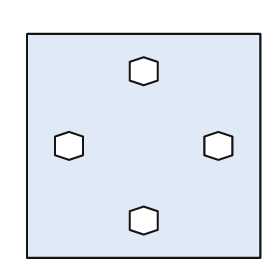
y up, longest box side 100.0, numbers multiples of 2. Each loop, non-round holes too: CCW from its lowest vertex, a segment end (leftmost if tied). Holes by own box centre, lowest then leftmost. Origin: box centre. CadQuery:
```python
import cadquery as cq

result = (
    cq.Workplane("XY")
    .moveTo(-50.0, -48.0)
    .lineTo(50.0, -48.0)
    .lineTo(50.0, 48.0)
    .lineTo(-50.0, 48.0)
    .close()
    .moveTo(0.0, -38.0)
    .lineTo(6.0, -36.0)
    .lineTo(6.0, -28.0)
    .lineTo(0.0, -26.0)
    .lineTo(-6.0, -28.0)
    .lineTo(-6.0, -36.0)
    .close()
    .moveTo(-32.0, -6.0)
    .lineTo(-26.0, -4.0)
    .lineTo(-26.0, 4.0)
    .lineTo(-32.0, 6.0)
    .lineTo(-38.0, 4.0)
    .lineTo(-38.0, -4.0)
    .close()
    .moveTo(32.0, -6.0)
    .lineTo(38.0, -4.0)
    .lineTo(38.0, 4.0)
    .lineTo(32.0, 6.0)
    .lineTo(26.0, 4.0)
    .lineTo(26.0, -4.0)
    .close()
    .moveTo(0.0, 26.0)
    .lineTo(6.0, 28.0)
    .lineTo(6.0, 36.0)
    .lineTo(0.0, 38.0)
    .lineTo(-6.0, 36.0)
    .lineTo(-6.0, 28.0)
    .close()
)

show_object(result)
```